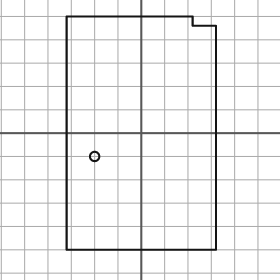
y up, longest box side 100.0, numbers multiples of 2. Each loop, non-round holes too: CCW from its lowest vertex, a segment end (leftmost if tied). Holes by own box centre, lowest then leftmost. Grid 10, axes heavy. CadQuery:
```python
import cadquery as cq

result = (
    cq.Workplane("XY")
    .moveTo(-32.0, -50.0)
    .lineTo(32.0, -50.0)
    .lineTo(32.0, 46.0)
    .lineTo(22.0, 46.0)
    .lineTo(22.0, 50.0)
    .lineTo(-32.0, 50.0)
    .close()
    .moveTo(-20.0, -10.0)
    .circle(2.0)
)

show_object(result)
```